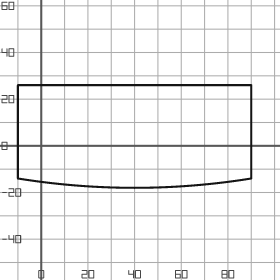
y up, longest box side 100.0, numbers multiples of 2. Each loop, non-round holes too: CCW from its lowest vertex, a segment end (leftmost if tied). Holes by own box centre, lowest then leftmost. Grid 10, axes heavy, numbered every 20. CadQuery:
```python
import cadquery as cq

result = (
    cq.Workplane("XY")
    .moveTo(-10.0, -14.0)
    .threePointArc((40.0, -18.0), (90.0, -14.0))
    .lineTo(90.0, 26.0)
    .lineTo(-10.0, 26.0)
    .close()
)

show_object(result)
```